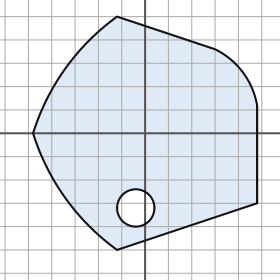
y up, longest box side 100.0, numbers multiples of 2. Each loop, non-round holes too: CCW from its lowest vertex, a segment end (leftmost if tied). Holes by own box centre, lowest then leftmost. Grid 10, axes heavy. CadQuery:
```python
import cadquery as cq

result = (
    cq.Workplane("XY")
    .moveTo(-12.0, -50.0)
    .lineTo(48.0, -30.0)
    .lineTo(48.0, 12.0)
    .threePointArc((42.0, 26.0), (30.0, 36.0))
    .lineTo(-12.0, 50.0)
    .threePointArc((-34.0, 28.0), (-48.0, 0.0))
    .threePointArc((-34.0, -28.0), (-12.0, -50.0))
    .close()
    .moveTo(-4.0, -32.0)
    .circle(8.0)
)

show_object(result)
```